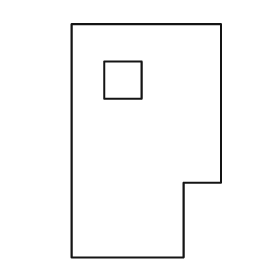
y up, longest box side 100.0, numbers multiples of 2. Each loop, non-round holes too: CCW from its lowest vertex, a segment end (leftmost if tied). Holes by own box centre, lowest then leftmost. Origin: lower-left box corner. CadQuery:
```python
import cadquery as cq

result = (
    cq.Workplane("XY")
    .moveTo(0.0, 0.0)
    .lineTo(48.0, 0.0)
    .lineTo(48.0, 32.0)
    .lineTo(64.0, 32.0)
    .lineTo(64.0, 100.0)
    .lineTo(0.0, 100.0)
    .close()
    .moveTo(14.0, 68.0)
    .lineTo(30.0, 68.0)
    .lineTo(30.0, 84.0)
    .lineTo(14.0, 84.0)
    .close()
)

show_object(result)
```